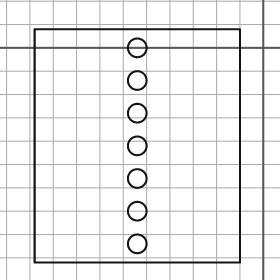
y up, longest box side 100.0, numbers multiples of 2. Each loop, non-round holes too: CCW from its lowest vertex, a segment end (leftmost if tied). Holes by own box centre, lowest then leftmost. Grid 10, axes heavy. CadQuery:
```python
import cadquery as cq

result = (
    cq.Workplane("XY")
    .moveTo(-98.0, -92.0)
    .lineTo(-10.0, -92.0)
    .lineTo(-10.0, 8.0)
    .lineTo(-98.0, 8.0)
    .close()
    .moveTo(-54.0, -84.0)
    .circle(4.0)
    .moveTo(-54.0, -70.0)
    .circle(4.0)
    .moveTo(-54.0, -56.0)
    .circle(4.0)
    .moveTo(-54.0, -42.0)
    .circle(4.0)
    .moveTo(-54.0, -28.0)
    .circle(4.0)
    .moveTo(-54.0, -14.0)
    .circle(4.0)
    .moveTo(-54.0, 0.0)
    .circle(4.0)
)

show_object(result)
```